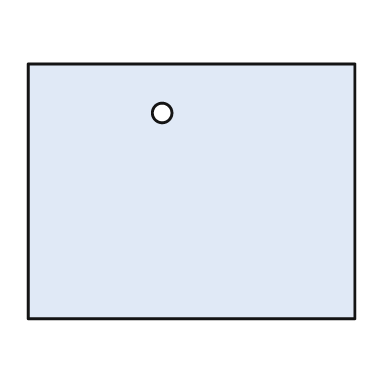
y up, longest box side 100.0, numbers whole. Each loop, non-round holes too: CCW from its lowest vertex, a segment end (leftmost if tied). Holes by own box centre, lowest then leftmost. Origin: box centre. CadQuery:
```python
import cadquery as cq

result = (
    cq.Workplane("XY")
    .moveTo(-50.0, -39.0)
    .lineTo(50.0, -39.0)
    .lineTo(50.0, 39.0)
    .lineTo(-50.0, 39.0)
    .close()
    .moveTo(-9.0, 24.0)
    .circle(3.0)
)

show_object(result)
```